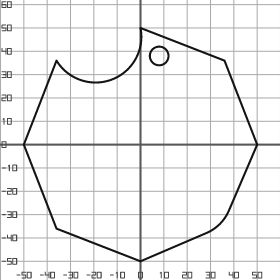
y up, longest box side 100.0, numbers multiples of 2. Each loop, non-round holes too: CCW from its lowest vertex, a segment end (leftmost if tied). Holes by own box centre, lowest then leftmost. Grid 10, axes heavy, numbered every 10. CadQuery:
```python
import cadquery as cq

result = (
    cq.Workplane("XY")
    .moveTo(0.0, -50.0)
    .lineTo(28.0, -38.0)
    .threePointArc((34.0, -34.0), (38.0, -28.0))
    .lineTo(50.0, 0.0)
    .lineTo(36.0, 36.0)
    .lineTo(0.0, 50.0)
    .threePointArc((-12.0, 28.0), (-36.0, 36.0))
    .lineTo(-50.0, 0.0)
    .lineTo(-36.0, -36.0)
    .close()
    .moveTo(8.0, 38.0)
    .circle(4.0)
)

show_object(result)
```